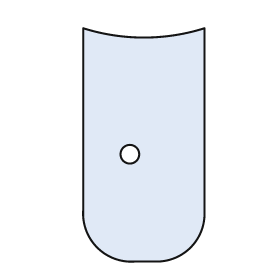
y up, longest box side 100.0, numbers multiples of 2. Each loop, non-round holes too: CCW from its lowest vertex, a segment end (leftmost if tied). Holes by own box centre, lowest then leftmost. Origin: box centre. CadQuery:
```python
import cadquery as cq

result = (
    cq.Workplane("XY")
    .moveTo(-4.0, -50.0)
    .lineTo(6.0, -50.0)
    .threePointArc((20.0, -44.0), (26.0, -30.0))
    .lineTo(26.0, 50.0)
    .threePointArc((0.0, 46.0), (-26.0, 50.0))
    .lineTo(-26.0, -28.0)
    .threePointArc((-20.0, -44.0), (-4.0, -50.0))
    .close()
    .moveTo(-6.0, -4.0)
    .circle(4.0)
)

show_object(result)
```